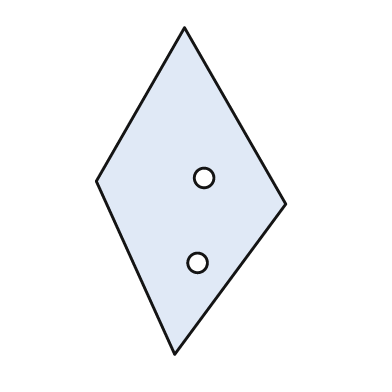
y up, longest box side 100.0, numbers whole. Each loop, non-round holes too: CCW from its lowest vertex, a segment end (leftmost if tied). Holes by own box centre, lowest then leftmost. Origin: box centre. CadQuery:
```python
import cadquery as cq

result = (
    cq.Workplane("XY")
    .moveTo(-5.0, -50.0)
    .lineTo(29.0, -4.0)
    .lineTo(-2.0, 50.0)
    .lineTo(-29.0, 3.0)
    .close()
    .moveTo(2.0, -22.0)
    .circle(3.0)
    .moveTo(4.0, 4.0)
    .circle(3.0)
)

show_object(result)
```